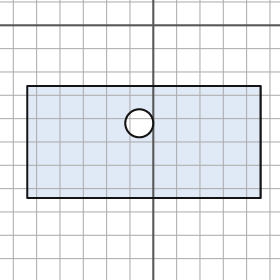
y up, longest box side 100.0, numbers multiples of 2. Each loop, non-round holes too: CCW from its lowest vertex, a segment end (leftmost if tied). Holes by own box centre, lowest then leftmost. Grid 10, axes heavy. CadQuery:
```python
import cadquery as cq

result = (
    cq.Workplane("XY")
    .moveTo(-54.0, -74.0)
    .lineTo(46.0, -74.0)
    .lineTo(46.0, -26.0)
    .lineTo(-54.0, -26.0)
    .close()
    .moveTo(-6.0, -42.0)
    .circle(6.0)
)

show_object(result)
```